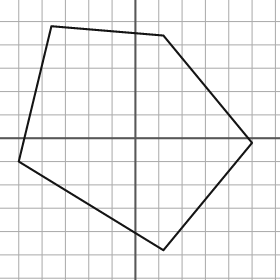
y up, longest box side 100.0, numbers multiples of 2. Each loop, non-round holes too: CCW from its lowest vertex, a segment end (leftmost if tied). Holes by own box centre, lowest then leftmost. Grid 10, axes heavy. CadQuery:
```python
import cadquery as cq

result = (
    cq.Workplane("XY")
    .moveTo(12.0, -48.0)
    .lineTo(50.0, -2.0)
    .lineTo(12.0, 44.0)
    .lineTo(-36.0, 48.0)
    .lineTo(-50.0, -10.0)
    .close()
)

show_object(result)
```